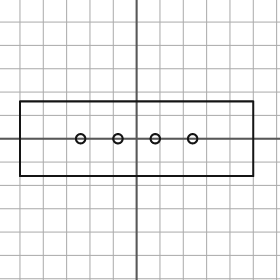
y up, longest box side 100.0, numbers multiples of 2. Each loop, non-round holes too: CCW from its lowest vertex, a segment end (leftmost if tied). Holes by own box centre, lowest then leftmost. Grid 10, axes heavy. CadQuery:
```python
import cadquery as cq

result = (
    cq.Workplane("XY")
    .moveTo(-50.0, -16.0)
    .lineTo(50.0, -16.0)
    .lineTo(50.0, 16.0)
    .lineTo(-50.0, 16.0)
    .close()
    .moveTo(-24.0, 0.0)
    .circle(2.0)
    .moveTo(-8.0, 0.0)
    .circle(2.0)
    .moveTo(8.0, 0.0)
    .circle(2.0)
    .moveTo(24.0, 0.0)
    .circle(2.0)
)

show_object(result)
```